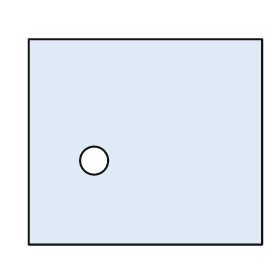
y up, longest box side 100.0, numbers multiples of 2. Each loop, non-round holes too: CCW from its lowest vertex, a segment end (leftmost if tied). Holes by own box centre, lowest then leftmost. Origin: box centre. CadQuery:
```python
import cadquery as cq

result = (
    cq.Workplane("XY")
    .moveTo(-50.0, -44.0)
    .lineTo(50.0, -44.0)
    .lineTo(50.0, 44.0)
    .lineTo(-50.0, 44.0)
    .close()
    .moveTo(-22.0, -8.0)
    .circle(6.0)
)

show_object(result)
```